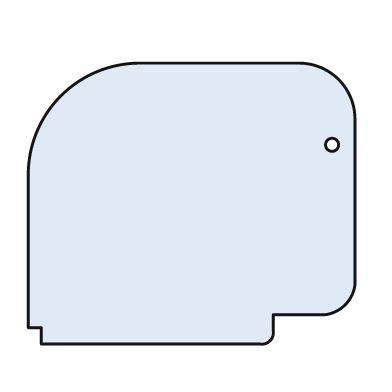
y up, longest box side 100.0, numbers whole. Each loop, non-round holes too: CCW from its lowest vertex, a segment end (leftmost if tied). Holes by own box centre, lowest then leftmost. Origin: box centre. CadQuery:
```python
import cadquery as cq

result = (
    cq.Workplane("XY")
    .moveTo(-46.0, -43.0)
    .lineTo(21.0, -43.0)
    .threePointArc((24.0, -42.0), (25.0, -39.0))
    .lineTo(25.0, -34.0)
    .lineTo(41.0, -34.0)
    .threePointArc((47.0, -31.0), (50.0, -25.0))
    .lineTo(50.0, 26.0)
    .threePointArc((45.0, 38.0), (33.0, 43.0))
    .lineTo(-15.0, 43.0)
    .threePointArc((-40.0, 33.0), (-50.0, 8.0))
    .lineTo(-50.0, -38.0)
    .lineTo(-46.0, -38.0)
    .close()
    .moveTo(43.0, 18.0)
    .circle(2.0)
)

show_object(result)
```